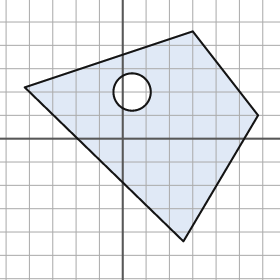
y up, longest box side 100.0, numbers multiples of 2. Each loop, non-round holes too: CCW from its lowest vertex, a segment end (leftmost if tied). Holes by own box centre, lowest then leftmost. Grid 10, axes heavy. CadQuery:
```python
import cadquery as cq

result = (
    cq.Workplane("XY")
    .moveTo(26.0, -44.0)
    .lineTo(58.0, 10.0)
    .lineTo(30.0, 46.0)
    .lineTo(-42.0, 22.0)
    .close()
    .moveTo(4.0, 20.0)
    .circle(8.0)
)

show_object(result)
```